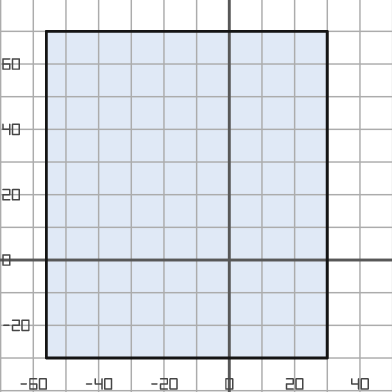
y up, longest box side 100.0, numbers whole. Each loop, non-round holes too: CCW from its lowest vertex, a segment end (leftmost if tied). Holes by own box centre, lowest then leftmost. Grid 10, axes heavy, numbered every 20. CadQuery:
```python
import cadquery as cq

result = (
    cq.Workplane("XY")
    .moveTo(-56.0, -30.0)
    .lineTo(30.0, -30.0)
    .lineTo(30.0, 70.0)
    .lineTo(-56.0, 70.0)
    .close()
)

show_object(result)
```